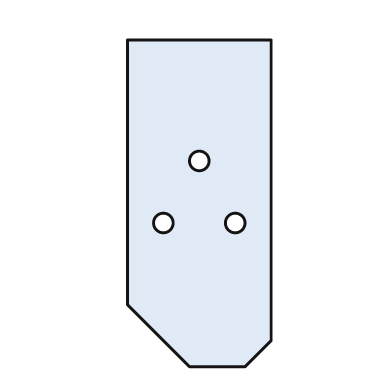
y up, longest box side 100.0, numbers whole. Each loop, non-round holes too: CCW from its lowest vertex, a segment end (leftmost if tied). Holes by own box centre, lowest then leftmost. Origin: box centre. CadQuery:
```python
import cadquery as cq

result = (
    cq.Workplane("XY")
    .moveTo(-3.0, -50.0)
    .lineTo(14.0, -50.0)
    .lineTo(22.0, -42.0)
    .lineTo(22.0, 50.0)
    .lineTo(-22.0, 50.0)
    .lineTo(-22.0, -31.0)
    .close()
    .moveTo(-11.0, -6.0)
    .circle(3.0)
    .moveTo(11.0, -6.0)
    .circle(3.0)
    .moveTo(0.0, 13.0)
    .circle(3.0)
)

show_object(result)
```